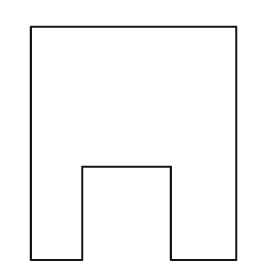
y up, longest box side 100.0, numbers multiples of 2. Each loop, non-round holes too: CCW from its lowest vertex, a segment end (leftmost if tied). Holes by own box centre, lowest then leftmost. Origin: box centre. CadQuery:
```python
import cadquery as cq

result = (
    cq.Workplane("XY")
    .moveTo(-44.0, -50.0)
    .lineTo(-22.0, -50.0)
    .lineTo(-22.0, -10.0)
    .lineTo(16.0, -10.0)
    .lineTo(16.0, -50.0)
    .lineTo(44.0, -50.0)
    .lineTo(44.0, 50.0)
    .lineTo(-44.0, 50.0)
    .close()
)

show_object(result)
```